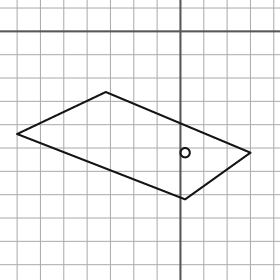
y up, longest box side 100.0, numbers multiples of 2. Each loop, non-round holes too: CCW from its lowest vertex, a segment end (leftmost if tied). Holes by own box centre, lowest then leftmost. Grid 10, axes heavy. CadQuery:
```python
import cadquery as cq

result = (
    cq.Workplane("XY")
    .moveTo(2.0, -72.0)
    .lineTo(30.0, -52.0)
    .lineTo(-32.0, -26.0)
    .lineTo(-70.0, -44.0)
    .close()
    .moveTo(2.0, -52.0)
    .circle(2.0)
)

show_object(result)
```